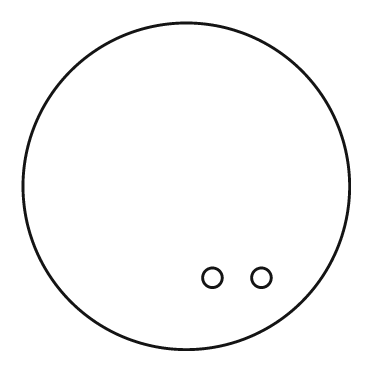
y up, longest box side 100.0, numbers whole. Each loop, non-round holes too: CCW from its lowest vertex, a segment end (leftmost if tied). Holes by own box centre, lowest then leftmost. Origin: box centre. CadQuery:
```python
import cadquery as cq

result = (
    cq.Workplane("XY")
    .moveTo(0.0, 0.0)
    .circle(50.0)
    .moveTo(8.0, -28.0)
    .circle(3.0)
    .moveTo(23.0, -28.0)
    .circle(3.0)
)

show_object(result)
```